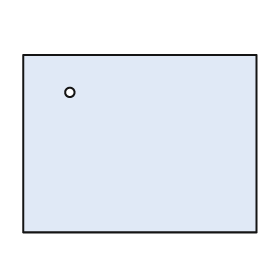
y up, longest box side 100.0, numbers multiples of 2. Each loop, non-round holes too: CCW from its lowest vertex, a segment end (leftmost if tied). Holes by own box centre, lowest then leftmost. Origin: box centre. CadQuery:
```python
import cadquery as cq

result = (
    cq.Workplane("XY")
    .moveTo(-50.0, -38.0)
    .lineTo(50.0, -38.0)
    .lineTo(50.0, 38.0)
    .lineTo(-50.0, 38.0)
    .close()
    .moveTo(-30.0, 22.0)
    .circle(2.0)
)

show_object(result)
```